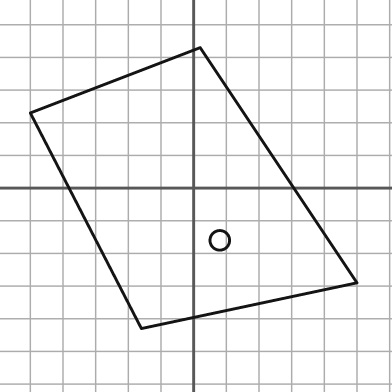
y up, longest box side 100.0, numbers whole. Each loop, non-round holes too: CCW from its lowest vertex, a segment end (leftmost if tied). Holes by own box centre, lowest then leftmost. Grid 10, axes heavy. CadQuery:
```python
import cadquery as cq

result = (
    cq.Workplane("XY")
    .moveTo(-16.0, -43.0)
    .lineTo(50.0, -29.0)
    .lineTo(2.0, 43.0)
    .lineTo(-50.0, 23.0)
    .close()
    .moveTo(8.0, -16.0)
    .circle(3.0)
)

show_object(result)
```